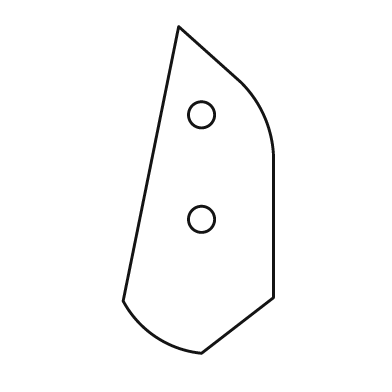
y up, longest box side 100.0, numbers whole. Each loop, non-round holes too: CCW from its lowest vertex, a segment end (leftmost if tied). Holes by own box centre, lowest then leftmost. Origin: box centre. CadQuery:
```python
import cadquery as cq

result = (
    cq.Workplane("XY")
    .moveTo(1.0, -50.0)
    .lineTo(23.0, -33.0)
    .lineTo(23.0, 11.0)
    .threePointArc((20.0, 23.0), (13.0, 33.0))
    .lineTo(-6.0, 50.0)
    .lineTo(-23.0, -34.0)
    .threePointArc((-13.0, -45.0), (1.0, -50.0))
    .close()
    .moveTo(1.0, -9.0)
    .circle(4.0)
    .moveTo(1.0, 23.0)
    .circle(4.0)
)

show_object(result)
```